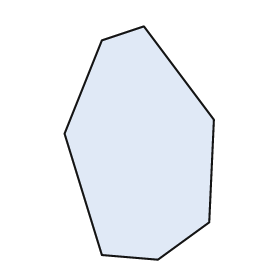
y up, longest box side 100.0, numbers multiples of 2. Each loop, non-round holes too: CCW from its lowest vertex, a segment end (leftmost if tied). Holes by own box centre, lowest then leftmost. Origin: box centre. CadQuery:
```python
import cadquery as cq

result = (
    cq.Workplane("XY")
    .moveTo(8.0, -50.0)
    .lineTo(30.0, -34.0)
    .lineTo(32.0, 10.0)
    .lineTo(2.0, 50.0)
    .lineTo(-16.0, 44.0)
    .lineTo(-32.0, 4.0)
    .lineTo(-16.0, -48.0)
    .close()
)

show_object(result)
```